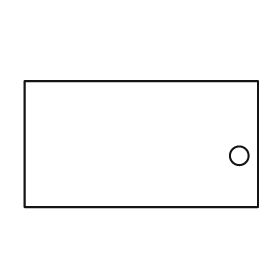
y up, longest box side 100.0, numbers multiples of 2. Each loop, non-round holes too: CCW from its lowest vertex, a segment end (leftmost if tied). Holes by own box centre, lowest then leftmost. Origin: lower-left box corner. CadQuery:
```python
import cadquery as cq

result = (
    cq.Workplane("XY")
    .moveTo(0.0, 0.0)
    .lineTo(100.0, 0.0)
    .lineTo(100.0, 54.0)
    .lineTo(0.0, 54.0)
    .close()
    .moveTo(92.0, 22.0)
    .circle(4.0)
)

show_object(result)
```